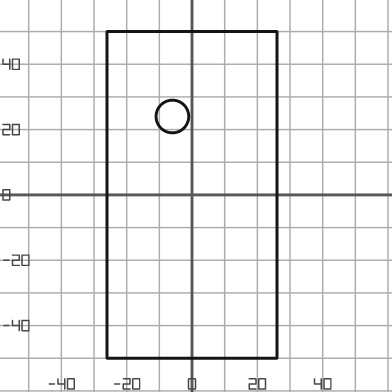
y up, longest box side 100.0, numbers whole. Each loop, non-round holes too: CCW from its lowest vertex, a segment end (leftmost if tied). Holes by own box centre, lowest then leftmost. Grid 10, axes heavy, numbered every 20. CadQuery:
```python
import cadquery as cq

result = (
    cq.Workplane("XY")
    .moveTo(-26.0, -50.0)
    .lineTo(26.0, -50.0)
    .lineTo(26.0, 50.0)
    .lineTo(-26.0, 50.0)
    .close()
    .moveTo(-6.0, 24.0)
    .circle(5.0)
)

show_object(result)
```